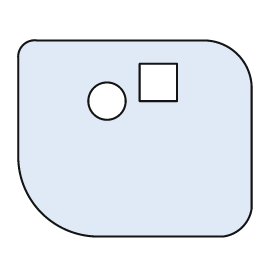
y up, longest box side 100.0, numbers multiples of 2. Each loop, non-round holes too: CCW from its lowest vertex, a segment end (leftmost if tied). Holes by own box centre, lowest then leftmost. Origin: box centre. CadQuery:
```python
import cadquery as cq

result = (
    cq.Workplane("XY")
    .moveTo(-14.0, -42.0)
    .lineTo(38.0, -42.0)
    .threePointArc((46.0, -38.0), (50.0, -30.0))
    .lineTo(50.0, 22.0)
    .threePointArc((44.0, 36.0), (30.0, 42.0))
    .lineTo(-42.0, 42.0)
    .threePointArc((-48.0, 40.0), (-50.0, 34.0))
    .lineTo(-50.0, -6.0)
    .threePointArc((-40.0, -32.0), (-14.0, -42.0))
    .close()
    .moveTo(-12.0, 16.0)
    .circle(8.0)
    .moveTo(2.0, 16.0)
    .lineTo(18.0, 16.0)
    .lineTo(18.0, 32.0)
    .lineTo(2.0, 32.0)
    .close()
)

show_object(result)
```